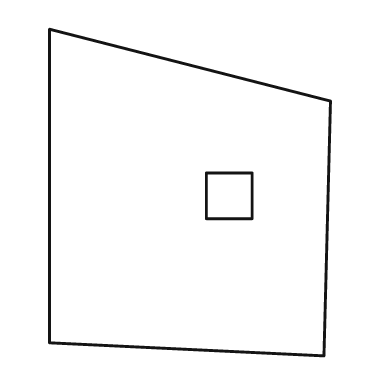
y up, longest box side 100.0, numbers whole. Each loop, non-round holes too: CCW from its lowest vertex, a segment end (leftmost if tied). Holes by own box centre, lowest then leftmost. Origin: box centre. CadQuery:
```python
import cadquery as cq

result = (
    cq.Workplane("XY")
    .moveTo(41.0, -50.0)
    .lineTo(43.0, 28.0)
    .lineTo(-43.0, 50.0)
    .lineTo(-43.0, -46.0)
    .close()
    .moveTo(5.0, -8.0)
    .lineTo(19.0, -8.0)
    .lineTo(19.0, 6.0)
    .lineTo(5.0, 6.0)
    .close()
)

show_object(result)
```